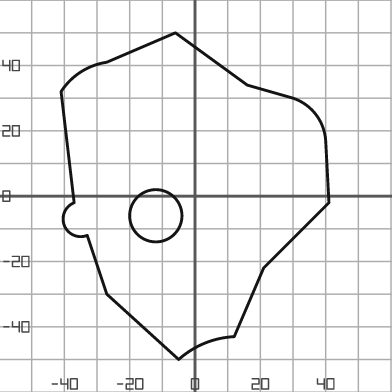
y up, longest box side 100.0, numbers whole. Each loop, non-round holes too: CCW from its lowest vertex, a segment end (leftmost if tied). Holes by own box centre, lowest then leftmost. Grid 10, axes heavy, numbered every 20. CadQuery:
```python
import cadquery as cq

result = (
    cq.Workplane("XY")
    .moveTo(-5.0, -50.0)
    .threePointArc((3.0, -45.0), (12.0, -43.0))
    .lineTo(21.0, -22.0)
    .lineTo(41.0, -2.0)
    .lineTo(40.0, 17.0)
    .threePointArc((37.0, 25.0), (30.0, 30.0))
    .lineTo(16.0, 34.0)
    .lineTo(-6.0, 50.0)
    .lineTo(-27.0, 41.0)
    .threePointArc((-35.0, 38.0), (-41.0, 32.0))
    .lineTo(-37.0, -2.0)
    .threePointArc((-40.0, -9.0), (-33.0, -12.0))
    .lineTo(-27.0, -30.0)
    .close()
    .moveTo(-12.0, -6.0)
    .circle(8.0)
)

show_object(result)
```